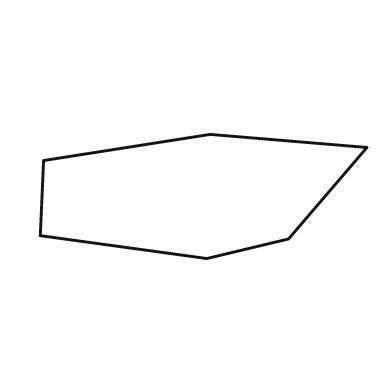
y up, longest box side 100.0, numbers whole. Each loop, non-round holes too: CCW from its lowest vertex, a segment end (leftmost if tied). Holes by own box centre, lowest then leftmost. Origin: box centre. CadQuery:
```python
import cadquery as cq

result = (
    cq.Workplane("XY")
    .moveTo(1.0, -19.0)
    .lineTo(26.0, -13.0)
    .lineTo(50.0, 15.0)
    .lineTo(2.0, 19.0)
    .lineTo(-49.0, 11.0)
    .lineTo(-50.0, -12.0)
    .close()
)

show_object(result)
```